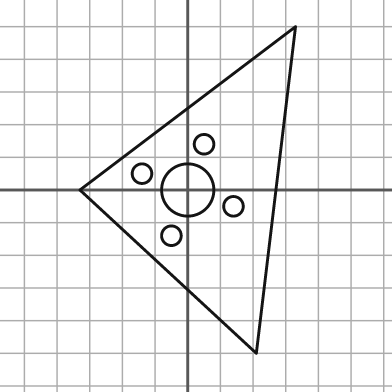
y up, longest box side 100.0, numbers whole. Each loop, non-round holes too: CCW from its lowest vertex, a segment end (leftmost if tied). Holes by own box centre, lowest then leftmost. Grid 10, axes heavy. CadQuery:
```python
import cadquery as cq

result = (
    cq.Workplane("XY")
    .moveTo(21.0, -50.0)
    .lineTo(33.0, 50.0)
    .lineTo(-33.0, 0.0)
    .close()
    .moveTo(-5.0, -14.0)
    .circle(3.0)
    .moveTo(14.0, -5.0)
    .circle(3.0)
    .moveTo(0.0, 0.0)
    .circle(8.0)
    .moveTo(-14.0, 5.0)
    .circle(3.0)
    .moveTo(5.0, 14.0)
    .circle(3.0)
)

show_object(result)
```